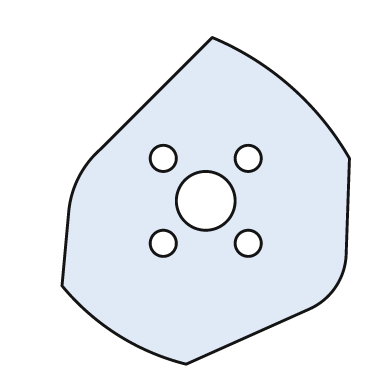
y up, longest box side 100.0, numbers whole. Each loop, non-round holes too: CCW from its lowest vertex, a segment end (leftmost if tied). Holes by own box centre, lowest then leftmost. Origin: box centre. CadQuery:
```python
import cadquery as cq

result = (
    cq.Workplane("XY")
    .moveTo(-6.0, -50.0)
    .lineTo(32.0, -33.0)
    .threePointArc((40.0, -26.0), (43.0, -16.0))
    .lineTo(44.0, 13.0)
    .threePointArc((26.0, 35.0), (2.0, 50.0))
    .lineTo(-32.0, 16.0)
    .threePointArc((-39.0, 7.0), (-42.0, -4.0))
    .lineTo(-44.0, -26.0)
    .threePointArc((-27.0, -41.0), (-6.0, -50.0))
    .close()
    .moveTo(-13.0, -13.0)
    .circle(4.0)
    .moveTo(13.0, -13.0)
    .circle(4.0)
    .moveTo(0.0, 0.0)
    .circle(9.0)
    .moveTo(-13.0, 13.0)
    .circle(4.0)
    .moveTo(13.0, 13.0)
    .circle(4.0)
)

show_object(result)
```